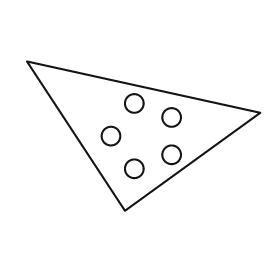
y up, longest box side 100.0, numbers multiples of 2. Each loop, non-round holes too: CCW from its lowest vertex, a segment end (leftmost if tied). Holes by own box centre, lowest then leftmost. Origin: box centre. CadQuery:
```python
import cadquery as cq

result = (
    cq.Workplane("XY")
    .moveTo(-8.0, -32.0)
    .lineTo(50.0, 10.0)
    .lineTo(-50.0, 32.0)
    .close()
    .moveTo(-4.0, -14.0)
    .circle(4.0)
    .moveTo(12.0, -8.0)
    .circle(4.0)
    .moveTo(-14.0, 0.0)
    .circle(4.0)
    .moveTo(12.0, 8.0)
    .circle(4.0)
    .moveTo(-4.0, 14.0)
    .circle(4.0)
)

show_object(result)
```